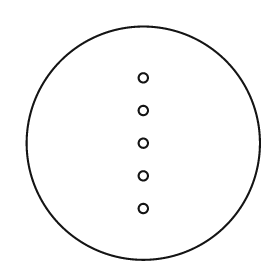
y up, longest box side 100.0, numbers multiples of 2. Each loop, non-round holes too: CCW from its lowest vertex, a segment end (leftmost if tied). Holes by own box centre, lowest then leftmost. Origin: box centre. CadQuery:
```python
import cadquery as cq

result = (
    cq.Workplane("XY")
    .moveTo(0.0, 0.0)
    .circle(50.0)
    .moveTo(0.0, -28.0)
    .circle(2.0)
    .moveTo(0.0, -14.0)
    .circle(2.0)
    .moveTo(0.0, 0.0)
    .circle(2.0)
    .moveTo(0.0, 14.0)
    .circle(2.0)
    .moveTo(0.0, 28.0)
    .circle(2.0)
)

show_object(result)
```